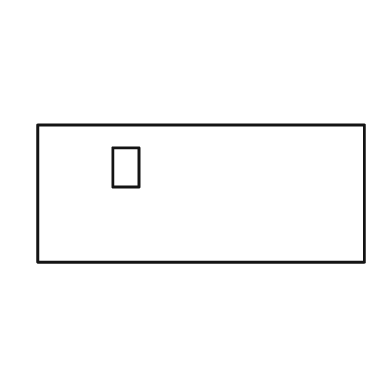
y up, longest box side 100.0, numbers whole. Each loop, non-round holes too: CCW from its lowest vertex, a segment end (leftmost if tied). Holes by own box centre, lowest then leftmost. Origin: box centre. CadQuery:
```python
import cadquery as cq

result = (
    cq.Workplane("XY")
    .moveTo(-50.0, -21.0)
    .lineTo(50.0, -21.0)
    .lineTo(50.0, 21.0)
    .lineTo(-50.0, 21.0)
    .close()
    .moveTo(-27.0, 2.0)
    .lineTo(-19.0, 2.0)
    .lineTo(-19.0, 14.0)
    .lineTo(-27.0, 14.0)
    .close()
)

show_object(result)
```